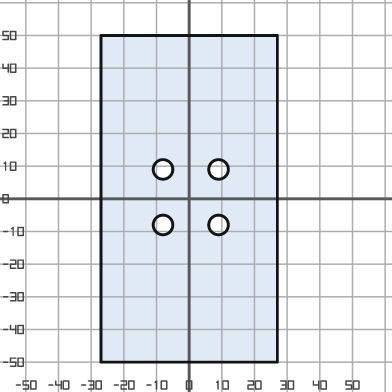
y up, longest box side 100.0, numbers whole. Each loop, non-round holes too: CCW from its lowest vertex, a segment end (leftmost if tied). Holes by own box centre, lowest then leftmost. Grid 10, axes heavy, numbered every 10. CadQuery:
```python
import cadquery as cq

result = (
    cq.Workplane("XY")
    .moveTo(-27.0, -50.0)
    .lineTo(27.0, -50.0)
    .lineTo(27.0, 50.0)
    .lineTo(-27.0, 50.0)
    .close()
    .moveTo(-8.0, -8.0)
    .circle(3.0)
    .moveTo(9.0, -8.0)
    .circle(3.0)
    .moveTo(-8.0, 9.0)
    .circle(3.0)
    .moveTo(9.0, 9.0)
    .circle(3.0)
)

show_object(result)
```